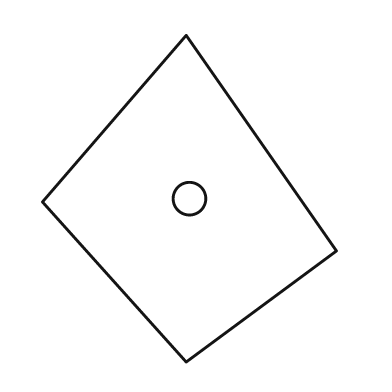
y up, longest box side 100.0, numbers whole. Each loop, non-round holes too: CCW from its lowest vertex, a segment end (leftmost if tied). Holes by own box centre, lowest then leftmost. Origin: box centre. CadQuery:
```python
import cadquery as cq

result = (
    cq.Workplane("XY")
    .moveTo(-1.0, -50.0)
    .lineTo(45.0, -16.0)
    .lineTo(-1.0, 50.0)
    .lineTo(-45.0, -1.0)
    .close()
    .moveTo(0.0, 0.0)
    .circle(5.0)
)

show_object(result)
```